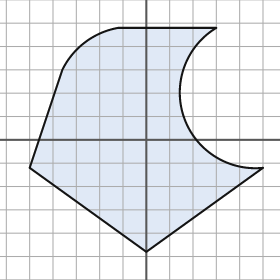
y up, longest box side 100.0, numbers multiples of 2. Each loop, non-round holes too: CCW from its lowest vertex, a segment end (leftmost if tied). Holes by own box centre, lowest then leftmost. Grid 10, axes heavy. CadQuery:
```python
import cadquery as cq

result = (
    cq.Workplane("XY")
    .moveTo(0.0, -48.0)
    .lineTo(50.0, -12.0)
    .threePointArc((16.0, 10.0), (30.0, 48.0))
    .lineTo(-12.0, 48.0)
    .threePointArc((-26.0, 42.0), (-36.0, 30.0))
    .lineTo(-50.0, -12.0)
    .close()
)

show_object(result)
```